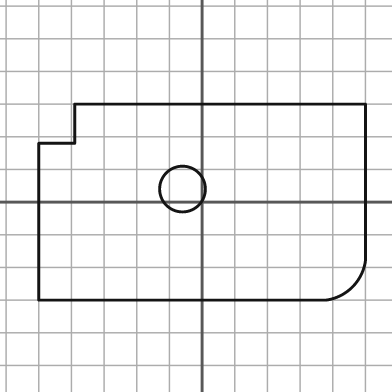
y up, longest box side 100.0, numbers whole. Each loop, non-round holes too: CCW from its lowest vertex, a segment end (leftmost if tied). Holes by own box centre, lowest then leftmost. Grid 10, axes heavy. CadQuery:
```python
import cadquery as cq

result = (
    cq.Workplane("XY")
    .moveTo(-50.0, -30.0)
    .lineTo(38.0, -30.0)
    .threePointArc((46.0, -26.0), (50.0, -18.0))
    .lineTo(50.0, 30.0)
    .lineTo(-39.0, 30.0)
    .lineTo(-39.0, 18.0)
    .lineTo(-50.0, 18.0)
    .close()
    .moveTo(-6.0, 4.0)
    .circle(7.0)
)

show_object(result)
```